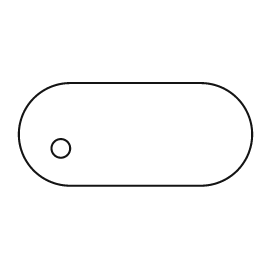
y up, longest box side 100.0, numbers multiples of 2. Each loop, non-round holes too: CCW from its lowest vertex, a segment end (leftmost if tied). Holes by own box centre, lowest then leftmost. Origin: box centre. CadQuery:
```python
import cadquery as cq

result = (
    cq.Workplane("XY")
    .moveTo(-28.0, -22.0)
    .lineTo(28.0, -22.0)
    .threePointArc((50.0, 0.0), (28.0, 22.0))
    .lineTo(-28.0, 22.0)
    .threePointArc((-50.0, 0.0), (-28.0, -22.0))
    .close()
    .moveTo(-32.0, -6.0)
    .circle(4.0)
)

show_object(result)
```